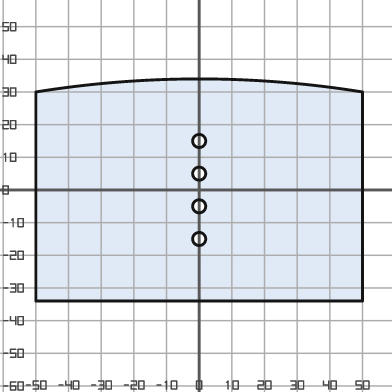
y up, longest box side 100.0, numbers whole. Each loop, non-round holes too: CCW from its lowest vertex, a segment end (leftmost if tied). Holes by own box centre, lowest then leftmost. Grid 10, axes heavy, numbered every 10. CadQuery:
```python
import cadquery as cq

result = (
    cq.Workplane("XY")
    .moveTo(-50.0, -34.0)
    .lineTo(50.0, -34.0)
    .lineTo(50.0, 30.0)
    .threePointArc((0.0, 34.0), (-50.0, 30.0))
    .close()
    .moveTo(0.0, -15.0)
    .circle(2.0)
    .moveTo(0.0, -5.0)
    .circle(2.0)
    .moveTo(0.0, 5.0)
    .circle(2.0)
    .moveTo(0.0, 15.0)
    .circle(2.0)
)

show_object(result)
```